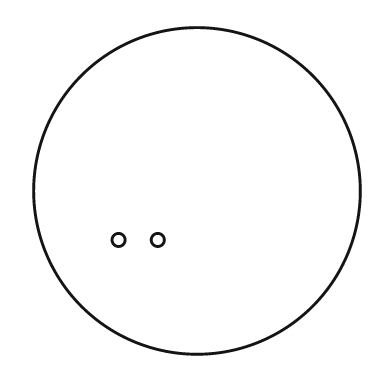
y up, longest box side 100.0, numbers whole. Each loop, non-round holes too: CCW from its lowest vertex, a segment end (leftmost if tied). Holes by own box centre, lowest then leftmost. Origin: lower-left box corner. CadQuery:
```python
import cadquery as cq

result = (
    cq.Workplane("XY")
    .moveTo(50.0, 50.0)
    .circle(50.0)
    .moveTo(26.0, 35.0)
    .circle(2.0)
    .moveTo(38.0, 35.0)
    .circle(2.0)
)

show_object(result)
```